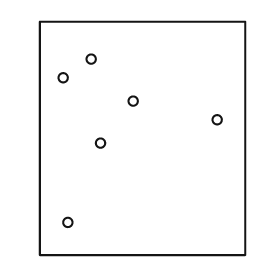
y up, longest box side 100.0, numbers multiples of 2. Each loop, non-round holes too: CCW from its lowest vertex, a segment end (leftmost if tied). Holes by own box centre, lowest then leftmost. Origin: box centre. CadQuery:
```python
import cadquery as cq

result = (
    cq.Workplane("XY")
    .moveTo(-44.0, -50.0)
    .lineTo(44.0, -50.0)
    .lineTo(44.0, 50.0)
    .lineTo(-44.0, 50.0)
    .close()
    .moveTo(-32.0, -36.0)
    .circle(2.0)
    .moveTo(-18.0, -2.0)
    .circle(2.0)
    .moveTo(32.0, 8.0)
    .circle(2.0)
    .moveTo(-4.0, 16.0)
    .circle(2.0)
    .moveTo(-34.0, 26.0)
    .circle(2.0)
    .moveTo(-22.0, 34.0)
    .circle(2.0)
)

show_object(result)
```